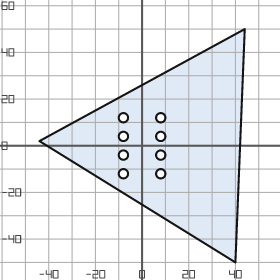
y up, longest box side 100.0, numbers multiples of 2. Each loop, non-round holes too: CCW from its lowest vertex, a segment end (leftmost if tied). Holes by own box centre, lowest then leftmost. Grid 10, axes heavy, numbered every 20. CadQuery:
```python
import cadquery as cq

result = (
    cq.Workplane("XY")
    .moveTo(40.0, -50.0)
    .lineTo(44.0, 50.0)
    .lineTo(-44.0, 2.0)
    .close()
    .moveTo(-8.0, -12.0)
    .circle(2.0)
    .moveTo(8.0, -12.0)
    .circle(2.0)
    .moveTo(-8.0, -4.0)
    .circle(2.0)
    .moveTo(8.0, -4.0)
    .circle(2.0)
    .moveTo(-8.0, 4.0)
    .circle(2.0)
    .moveTo(8.0, 4.0)
    .circle(2.0)
    .moveTo(-8.0, 12.0)
    .circle(2.0)
    .moveTo(8.0, 12.0)
    .circle(2.0)
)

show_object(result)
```